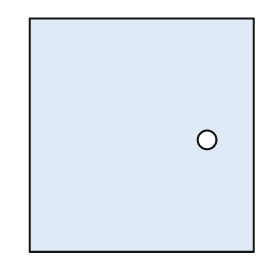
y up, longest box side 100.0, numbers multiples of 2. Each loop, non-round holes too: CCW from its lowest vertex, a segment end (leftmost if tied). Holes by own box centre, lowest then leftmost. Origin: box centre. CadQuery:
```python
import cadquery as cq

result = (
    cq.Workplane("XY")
    .moveTo(-48.0, -50.0)
    .lineTo(48.0, -50.0)
    .lineTo(48.0, 50.0)
    .lineTo(-48.0, 50.0)
    .close()
    .moveTo(28.0, -2.0)
    .circle(4.0)
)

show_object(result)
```